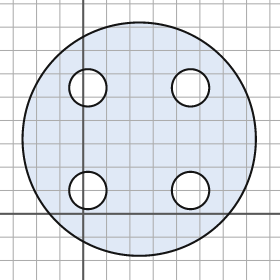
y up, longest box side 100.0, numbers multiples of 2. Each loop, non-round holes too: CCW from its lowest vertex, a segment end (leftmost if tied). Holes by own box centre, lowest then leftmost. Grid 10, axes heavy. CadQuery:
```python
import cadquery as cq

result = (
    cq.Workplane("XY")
    .moveTo(24.0, 32.0)
    .circle(50.0)
    .moveTo(2.0, 10.0)
    .circle(8.0)
    .moveTo(46.0, 10.0)
    .circle(8.0)
    .moveTo(2.0, 54.0)
    .circle(8.0)
    .moveTo(46.0, 54.0)
    .circle(8.0)
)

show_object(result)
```